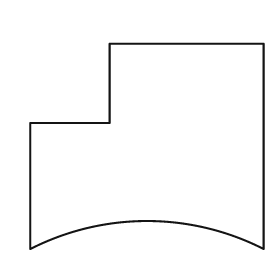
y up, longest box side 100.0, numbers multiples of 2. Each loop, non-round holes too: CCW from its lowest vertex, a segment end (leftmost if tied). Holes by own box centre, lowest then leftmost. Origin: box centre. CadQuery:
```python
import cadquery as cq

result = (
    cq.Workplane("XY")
    .moveTo(-50.0, -44.0)
    .threePointArc((0.0, -32.0), (50.0, -44.0))
    .lineTo(50.0, 44.0)
    .lineTo(-16.0, 44.0)
    .lineTo(-16.0, 10.0)
    .lineTo(-50.0, 10.0)
    .close()
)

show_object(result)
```